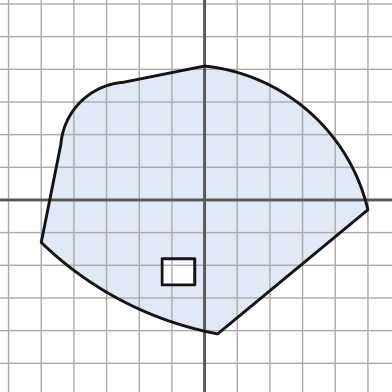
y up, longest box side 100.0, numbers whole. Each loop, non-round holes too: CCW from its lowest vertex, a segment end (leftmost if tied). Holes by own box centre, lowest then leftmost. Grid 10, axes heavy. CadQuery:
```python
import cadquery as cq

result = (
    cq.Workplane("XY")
    .moveTo(4.0, -41.0)
    .lineTo(50.0, -3.0)
    .threePointArc((32.0, 27.0), (0.0, 41.0))
    .lineTo(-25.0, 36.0)
    .threePointArc((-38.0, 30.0), (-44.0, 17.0))
    .lineTo(-50.0, -13.0)
    .threePointArc((-25.0, -31.0), (4.0, -41.0))
    .close()
    .moveTo(-13.0, -26.0)
    .lineTo(-3.0, -26.0)
    .lineTo(-3.0, -18.0)
    .lineTo(-13.0, -18.0)
    .close()
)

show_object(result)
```